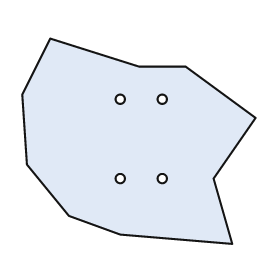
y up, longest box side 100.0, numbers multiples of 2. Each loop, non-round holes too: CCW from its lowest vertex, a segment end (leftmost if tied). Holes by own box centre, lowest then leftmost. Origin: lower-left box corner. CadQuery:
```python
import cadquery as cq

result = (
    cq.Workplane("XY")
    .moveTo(90.0, 0.0)
    .lineTo(82.0, 28.0)
    .lineTo(100.0, 54.0)
    .lineTo(70.0, 76.0)
    .lineTo(50.0, 76.0)
    .lineTo(12.0, 88.0)
    .lineTo(0.0, 64.0)
    .lineTo(2.0, 34.0)
    .lineTo(20.0, 12.0)
    .lineTo(42.0, 4.0)
    .close()
    .moveTo(42.0, 28.0)
    .circle(2.0)
    .moveTo(60.0, 28.0)
    .circle(2.0)
    .moveTo(42.0, 62.0)
    .circle(2.0)
    .moveTo(60.0, 62.0)
    .circle(2.0)
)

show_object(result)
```